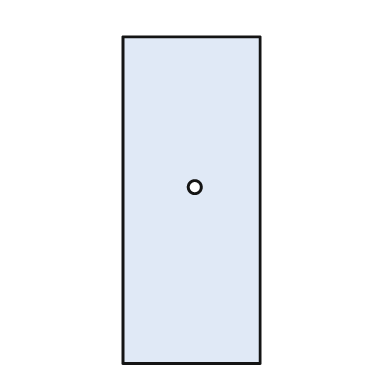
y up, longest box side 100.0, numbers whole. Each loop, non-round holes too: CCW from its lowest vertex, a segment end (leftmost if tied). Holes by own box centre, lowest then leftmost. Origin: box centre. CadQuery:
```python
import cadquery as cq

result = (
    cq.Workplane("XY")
    .moveTo(-21.0, -50.0)
    .lineTo(21.0, -50.0)
    .lineTo(21.0, 50.0)
    .lineTo(-21.0, 50.0)
    .close()
    .moveTo(1.0, 4.0)
    .circle(2.0)
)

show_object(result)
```